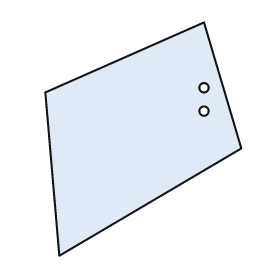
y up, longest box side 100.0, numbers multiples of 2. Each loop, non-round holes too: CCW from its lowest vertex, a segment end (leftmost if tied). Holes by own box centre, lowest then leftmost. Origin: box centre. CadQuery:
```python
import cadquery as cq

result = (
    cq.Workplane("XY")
    .moveTo(-36.0, -50.0)
    .lineTo(42.0, -4.0)
    .lineTo(26.0, 50.0)
    .lineTo(-42.0, 20.0)
    .close()
    .moveTo(26.0, 12.0)
    .circle(2.0)
    .moveTo(26.0, 22.0)
    .circle(2.0)
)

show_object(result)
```